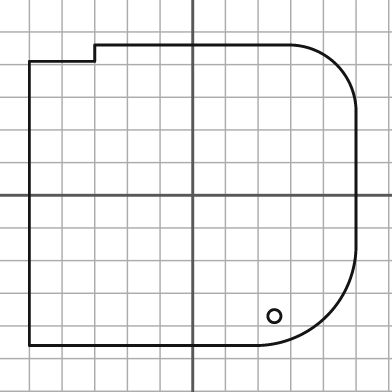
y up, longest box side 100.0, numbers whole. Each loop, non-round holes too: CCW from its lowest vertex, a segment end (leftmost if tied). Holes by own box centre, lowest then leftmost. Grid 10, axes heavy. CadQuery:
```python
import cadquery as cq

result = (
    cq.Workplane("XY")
    .moveTo(-50.0, -46.0)
    .lineTo(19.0, -46.0)
    .threePointArc((41.0, -37.0), (50.0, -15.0))
    .lineTo(50.0, 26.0)
    .threePointArc((44.0, 40.0), (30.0, 46.0))
    .lineTo(-30.0, 46.0)
    .lineTo(-30.0, 41.0)
    .lineTo(-50.0, 41.0)
    .close()
    .moveTo(25.0, -37.0)
    .circle(2.0)
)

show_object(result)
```